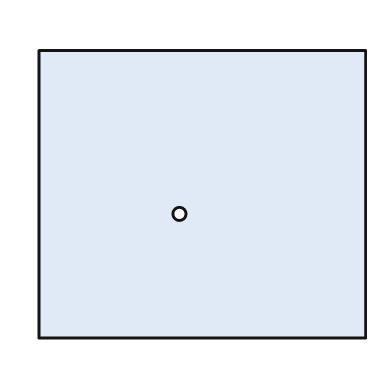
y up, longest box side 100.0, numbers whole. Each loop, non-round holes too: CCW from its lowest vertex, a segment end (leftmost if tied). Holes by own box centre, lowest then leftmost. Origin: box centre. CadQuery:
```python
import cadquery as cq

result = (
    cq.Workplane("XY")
    .moveTo(-50.0, -44.0)
    .lineTo(50.0, -44.0)
    .lineTo(50.0, 44.0)
    .lineTo(-50.0, 44.0)
    .close()
    .moveTo(-7.0, -6.0)
    .circle(2.0)
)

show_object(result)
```